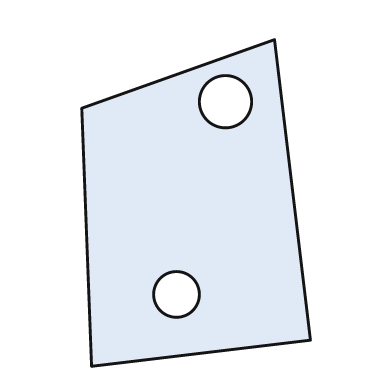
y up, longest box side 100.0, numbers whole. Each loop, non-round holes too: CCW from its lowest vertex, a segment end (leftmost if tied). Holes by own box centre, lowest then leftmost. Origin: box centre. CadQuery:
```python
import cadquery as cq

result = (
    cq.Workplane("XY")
    .moveTo(-32.0, -50.0)
    .lineTo(35.0, -42.0)
    .lineTo(24.0, 50.0)
    .lineTo(-35.0, 29.0)
    .close()
    .moveTo(-6.0, -28.0)
    .circle(7.0)
    .moveTo(9.0, 31.0)
    .circle(8.0)
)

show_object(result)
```